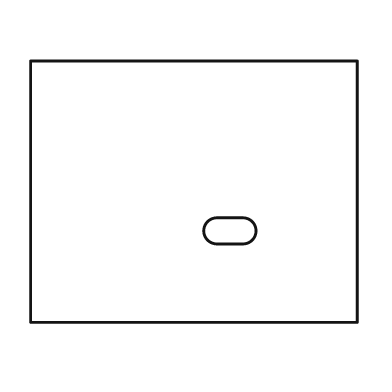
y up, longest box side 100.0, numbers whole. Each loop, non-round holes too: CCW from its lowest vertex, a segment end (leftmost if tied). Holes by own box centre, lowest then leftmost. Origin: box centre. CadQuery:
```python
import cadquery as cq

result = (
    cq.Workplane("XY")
    .moveTo(-50.0, -40.0)
    .lineTo(50.0, -40.0)
    .lineTo(50.0, 40.0)
    .lineTo(-50.0, 40.0)
    .close()
    .moveTo(7.0, -16.0)
    .lineTo(15.0, -16.0)
    .threePointArc((19.0, -12.0), (15.0, -8.0))
    .lineTo(7.0, -8.0)
    .threePointArc((3.0, -12.0), (7.0, -16.0))
    .close()
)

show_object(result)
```